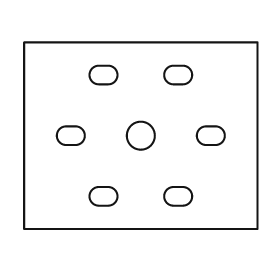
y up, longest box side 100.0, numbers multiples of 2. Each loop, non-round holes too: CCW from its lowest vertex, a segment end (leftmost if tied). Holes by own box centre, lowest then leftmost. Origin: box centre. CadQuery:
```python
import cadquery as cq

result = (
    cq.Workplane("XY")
    .moveTo(-50.0, -40.0)
    .lineTo(50.0, -40.0)
    .lineTo(50.0, 40.0)
    .lineTo(-50.0, 40.0)
    .close()
    .moveTo(-18.0, -30.0)
    .lineTo(-14.0, -30.0)
    .threePointArc((-10.0, -26.0), (-14.0, -22.0))
    .lineTo(-18.0, -22.0)
    .threePointArc((-22.0, -26.0), (-18.0, -30.0))
    .close()
    .moveTo(14.0, -30.0)
    .lineTo(18.0, -30.0)
    .threePointArc((22.0, -26.0), (18.0, -22.0))
    .lineTo(14.0, -22.0)
    .threePointArc((10.0, -26.0), (14.0, -30.0))
    .close()
    .moveTo(-32.0, -4.0)
    .lineTo(-28.0, -4.0)
    .threePointArc((-24.0, 0.0), (-28.0, 4.0))
    .lineTo(-32.0, 4.0)
    .threePointArc((-36.0, 0.0), (-32.0, -4.0))
    .close()
    .moveTo(0.0, 0.0)
    .circle(6.0)
    .moveTo(28.0, -4.0)
    .lineTo(32.0, -4.0)
    .threePointArc((36.0, 0.0), (32.0, 4.0))
    .lineTo(28.0, 4.0)
    .threePointArc((24.0, 0.0), (28.0, -4.0))
    .close()
    .moveTo(-18.0, 22.0)
    .lineTo(-14.0, 22.0)
    .threePointArc((-10.0, 26.0), (-14.0, 30.0))
    .lineTo(-18.0, 30.0)
    .threePointArc((-22.0, 26.0), (-18.0, 22.0))
    .close()
    .moveTo(14.0, 22.0)
    .lineTo(18.0, 22.0)
    .threePointArc((22.0, 26.0), (18.0, 30.0))
    .lineTo(14.0, 30.0)
    .threePointArc((10.0, 26.0), (14.0, 22.0))
    .close()
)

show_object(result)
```